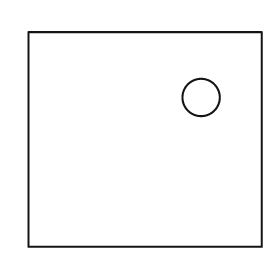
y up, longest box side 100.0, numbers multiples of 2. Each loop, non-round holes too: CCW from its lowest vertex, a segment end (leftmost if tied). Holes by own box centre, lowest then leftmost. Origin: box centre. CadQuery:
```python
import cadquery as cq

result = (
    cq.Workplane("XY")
    .moveTo(-50.0, -46.0)
    .lineTo(50.0, -46.0)
    .lineTo(50.0, 46.0)
    .lineTo(-50.0, 46.0)
    .close()
    .moveTo(24.0, 18.0)
    .circle(8.0)
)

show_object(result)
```